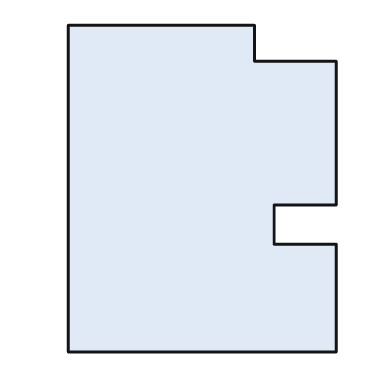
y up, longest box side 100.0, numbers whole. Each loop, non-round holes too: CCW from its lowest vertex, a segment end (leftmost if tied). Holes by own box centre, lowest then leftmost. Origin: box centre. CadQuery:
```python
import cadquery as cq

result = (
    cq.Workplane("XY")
    .moveTo(-41.0, -50.0)
    .lineTo(41.0, -50.0)
    .lineTo(41.0, -17.0)
    .lineTo(22.0, -17.0)
    .lineTo(22.0, -5.0)
    .lineTo(41.0, -5.0)
    .lineTo(41.0, 39.0)
    .lineTo(16.0, 39.0)
    .lineTo(16.0, 50.0)
    .lineTo(-41.0, 50.0)
    .close()
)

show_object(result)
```